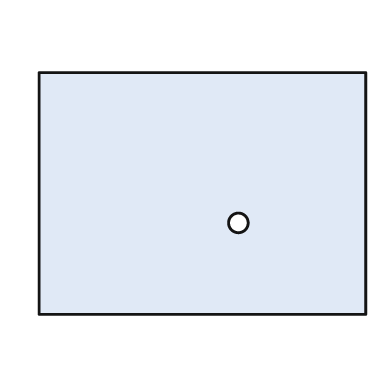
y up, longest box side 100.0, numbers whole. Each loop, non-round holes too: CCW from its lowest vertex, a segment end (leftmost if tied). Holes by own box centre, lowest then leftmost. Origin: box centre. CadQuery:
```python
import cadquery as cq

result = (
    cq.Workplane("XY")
    .moveTo(-50.0, -37.0)
    .lineTo(50.0, -37.0)
    .lineTo(50.0, 37.0)
    .lineTo(-50.0, 37.0)
    .close()
    .moveTo(11.0, -9.0)
    .circle(3.0)
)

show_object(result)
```